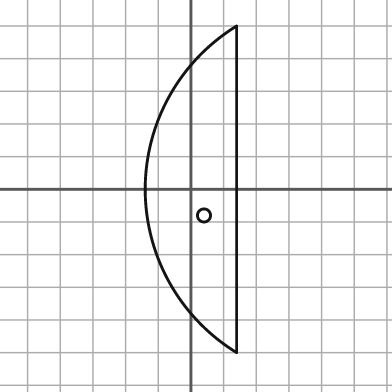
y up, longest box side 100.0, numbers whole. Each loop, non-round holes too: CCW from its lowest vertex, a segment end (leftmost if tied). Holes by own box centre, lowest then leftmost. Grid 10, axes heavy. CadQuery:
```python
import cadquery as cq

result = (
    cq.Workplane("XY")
    .moveTo(14.0, -50.0)
    .lineTo(14.0, 50.0)
    .threePointArc((-14.0, 0.0), (14.0, -50.0))
    .close()
    .moveTo(4.0, -8.0)
    .circle(2.0)
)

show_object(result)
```